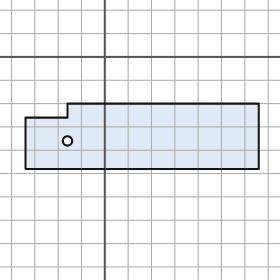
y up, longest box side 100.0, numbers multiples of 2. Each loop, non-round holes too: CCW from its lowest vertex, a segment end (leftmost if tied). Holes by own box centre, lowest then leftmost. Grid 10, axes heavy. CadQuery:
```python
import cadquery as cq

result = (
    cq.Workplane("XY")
    .moveTo(-34.0, -48.0)
    .lineTo(66.0, -48.0)
    .lineTo(66.0, -20.0)
    .lineTo(-16.0, -20.0)
    .lineTo(-16.0, -26.0)
    .lineTo(-34.0, -26.0)
    .close()
    .moveTo(-16.0, -36.0)
    .circle(2.0)
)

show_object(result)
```